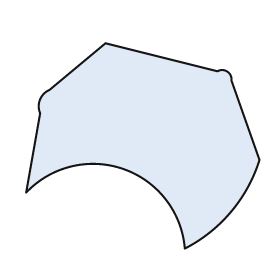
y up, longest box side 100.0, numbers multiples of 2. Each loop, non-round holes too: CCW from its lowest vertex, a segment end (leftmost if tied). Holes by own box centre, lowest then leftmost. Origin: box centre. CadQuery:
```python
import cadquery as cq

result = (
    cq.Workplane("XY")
    .moveTo(18.0, -44.0)
    .threePointArc((38.0, -28.0), (50.0, -6.0))
    .lineTo(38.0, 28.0)
    .threePointArc((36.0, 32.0), (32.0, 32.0))
    .lineTo(-16.0, 44.0)
    .lineTo(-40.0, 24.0)
    .threePointArc((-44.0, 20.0), (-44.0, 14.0))
    .lineTo(-50.0, -20.0)
    .threePointArc((-8.0, -10.0), (18.0, -44.0))
    .close()
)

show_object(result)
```